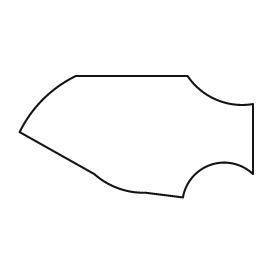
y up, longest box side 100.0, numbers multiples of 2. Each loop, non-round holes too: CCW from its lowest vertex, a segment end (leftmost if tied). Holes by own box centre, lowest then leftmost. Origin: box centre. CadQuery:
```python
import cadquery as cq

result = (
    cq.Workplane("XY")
    .moveTo(20.0, -26.0)
    .threePointArc((32.0, -12.0), (50.0, -16.0))
    .lineTo(50.0, 14.0)
    .threePointArc((34.0, 16.0), (22.0, 26.0))
    .lineTo(-26.0, 26.0)
    .threePointArc((-40.0, 16.0), (-50.0, 2.0))
    .lineTo(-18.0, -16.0)
    .threePointArc((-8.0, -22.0), (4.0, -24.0))
    .close()
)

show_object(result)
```